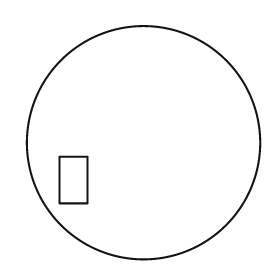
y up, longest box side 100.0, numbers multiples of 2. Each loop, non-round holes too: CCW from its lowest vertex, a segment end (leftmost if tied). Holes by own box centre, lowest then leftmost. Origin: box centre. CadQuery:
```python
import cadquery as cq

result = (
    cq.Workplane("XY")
    .moveTo(0.0, 0.0)
    .circle(50.0)
    .moveTo(-36.0, -26.0)
    .lineTo(-24.0, -26.0)
    .lineTo(-24.0, -6.0)
    .lineTo(-36.0, -6.0)
    .close()
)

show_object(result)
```